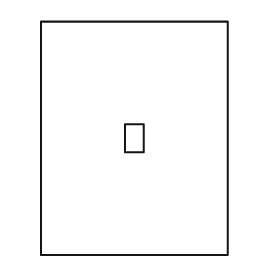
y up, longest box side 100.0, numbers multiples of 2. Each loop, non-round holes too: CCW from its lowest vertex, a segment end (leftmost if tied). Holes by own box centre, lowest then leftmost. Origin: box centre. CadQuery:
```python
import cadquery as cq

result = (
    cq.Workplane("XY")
    .moveTo(-40.0, -50.0)
    .lineTo(40.0, -50.0)
    .lineTo(40.0, 50.0)
    .lineTo(-40.0, 50.0)
    .close()
    .moveTo(-4.0, -6.0)
    .lineTo(4.0, -6.0)
    .lineTo(4.0, 6.0)
    .lineTo(-4.0, 6.0)
    .close()
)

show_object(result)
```